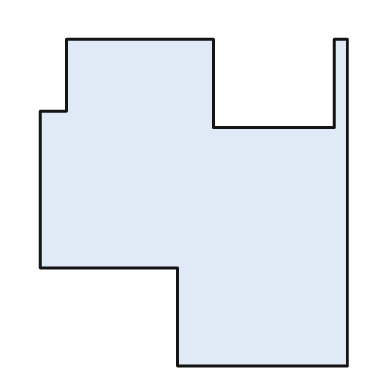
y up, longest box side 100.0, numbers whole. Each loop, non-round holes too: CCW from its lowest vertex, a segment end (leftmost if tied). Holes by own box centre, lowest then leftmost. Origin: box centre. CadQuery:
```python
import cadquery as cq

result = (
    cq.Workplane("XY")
    .moveTo(-5.0, -50.0)
    .lineTo(47.0, -50.0)
    .lineTo(47.0, 50.0)
    .lineTo(43.0, 50.0)
    .lineTo(43.0, 23.0)
    .lineTo(6.0, 23.0)
    .lineTo(6.0, 50.0)
    .lineTo(-39.0, 50.0)
    .lineTo(-39.0, 28.0)
    .lineTo(-47.0, 28.0)
    .lineTo(-47.0, -20.0)
    .lineTo(-5.0, -20.0)
    .close()
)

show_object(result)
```